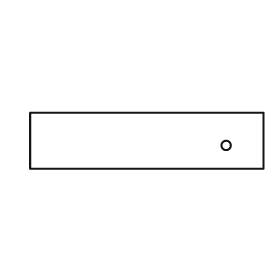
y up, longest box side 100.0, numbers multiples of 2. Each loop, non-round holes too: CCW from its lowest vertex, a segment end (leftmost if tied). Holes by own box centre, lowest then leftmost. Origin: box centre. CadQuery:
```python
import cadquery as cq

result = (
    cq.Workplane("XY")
    .moveTo(-50.0, -12.0)
    .lineTo(50.0, -12.0)
    .lineTo(50.0, 12.0)
    .lineTo(-50.0, 12.0)
    .close()
    .moveTo(34.0, -2.0)
    .circle(2.0)
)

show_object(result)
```